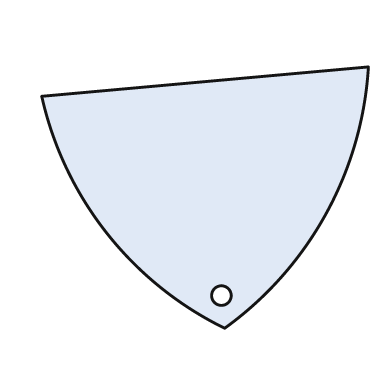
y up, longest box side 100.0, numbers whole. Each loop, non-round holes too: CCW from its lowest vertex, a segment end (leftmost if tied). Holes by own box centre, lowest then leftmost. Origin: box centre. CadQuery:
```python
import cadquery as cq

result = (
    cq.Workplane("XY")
    .moveTo(6.0, -40.0)
    .threePointArc((37.0, -5.0), (50.0, 40.0))
    .lineTo(-50.0, 31.0)
    .threePointArc((-30.0, -11.0), (6.0, -40.0))
    .close()
    .moveTo(5.0, -30.0)
    .circle(3.0)
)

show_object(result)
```